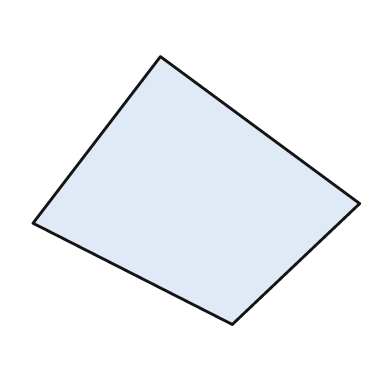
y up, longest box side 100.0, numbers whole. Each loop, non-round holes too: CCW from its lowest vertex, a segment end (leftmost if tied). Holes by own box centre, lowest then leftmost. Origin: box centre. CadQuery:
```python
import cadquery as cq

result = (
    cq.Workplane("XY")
    .moveTo(11.0, -41.0)
    .lineTo(50.0, -4.0)
    .lineTo(-11.0, 41.0)
    .lineTo(-50.0, -10.0)
    .close()
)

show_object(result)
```